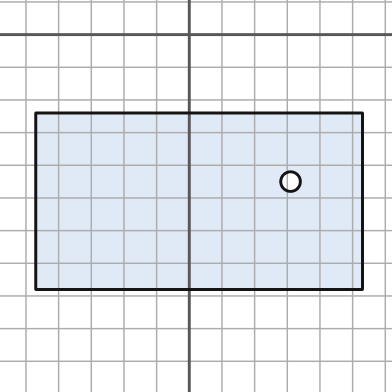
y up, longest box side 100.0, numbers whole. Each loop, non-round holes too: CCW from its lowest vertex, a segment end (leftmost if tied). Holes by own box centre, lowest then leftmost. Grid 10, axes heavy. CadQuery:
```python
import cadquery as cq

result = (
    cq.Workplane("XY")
    .moveTo(-47.0, -78.0)
    .lineTo(53.0, -78.0)
    .lineTo(53.0, -24.0)
    .lineTo(-47.0, -24.0)
    .close()
    .moveTo(31.0, -45.0)
    .circle(3.0)
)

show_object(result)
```